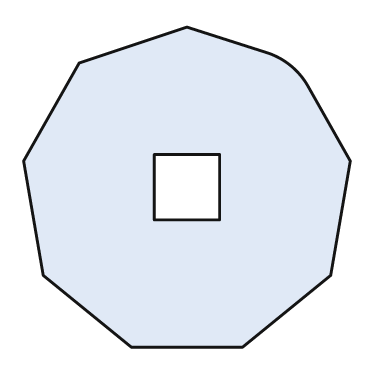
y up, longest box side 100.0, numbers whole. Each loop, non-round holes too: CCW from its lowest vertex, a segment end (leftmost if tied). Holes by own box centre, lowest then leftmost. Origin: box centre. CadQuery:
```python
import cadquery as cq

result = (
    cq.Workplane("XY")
    .moveTo(-17.0, -49.0)
    .lineTo(17.0, -49.0)
    .lineTo(44.0, -27.0)
    .lineTo(50.0, 8.0)
    .lineTo(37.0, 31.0)
    .threePointArc((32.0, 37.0), (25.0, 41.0))
    .lineTo(0.0, 49.0)
    .lineTo(-33.0, 38.0)
    .lineTo(-50.0, 8.0)
    .lineTo(-44.0, -27.0)
    .close()
    .moveTo(-10.0, -10.0)
    .lineTo(10.0, -10.0)
    .lineTo(10.0, 10.0)
    .lineTo(-10.0, 10.0)
    .close()
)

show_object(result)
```